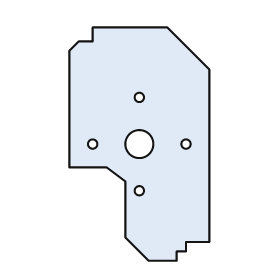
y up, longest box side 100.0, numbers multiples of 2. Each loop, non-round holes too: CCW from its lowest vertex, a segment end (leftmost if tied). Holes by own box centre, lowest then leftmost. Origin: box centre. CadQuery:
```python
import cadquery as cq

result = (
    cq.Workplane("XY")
    .moveTo(4.0, -50.0)
    .lineTo(16.0, -50.0)
    .lineTo(16.0, -46.0)
    .lineTo(20.0, -46.0)
    .lineTo(20.0, -42.0)
    .lineTo(30.0, -42.0)
    .lineTo(30.0, 32.0)
    .lineTo(12.0, 50.0)
    .lineTo(-20.0, 50.0)
    .lineTo(-20.0, 44.0)
    .lineTo(-26.0, 44.0)
    .lineTo(-30.0, 40.0)
    .lineTo(-30.0, -10.0)
    .lineTo(-14.0, -10.0)
    .lineTo(-6.0, -16.0)
    .lineTo(-6.0, -40.0)
    .close()
    .moveTo(0.0, -20.0)
    .circle(2.0)
    .moveTo(-20.0, 0.0)
    .circle(2.0)
    .moveTo(0.0, 0.0)
    .circle(6.0)
    .moveTo(20.0, 0.0)
    .circle(2.0)
    .moveTo(0.0, 20.0)
    .circle(2.0)
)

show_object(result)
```